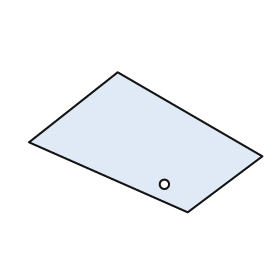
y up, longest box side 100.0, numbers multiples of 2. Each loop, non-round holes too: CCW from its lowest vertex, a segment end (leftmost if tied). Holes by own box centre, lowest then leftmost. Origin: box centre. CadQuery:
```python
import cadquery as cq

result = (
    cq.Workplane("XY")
    .moveTo(18.0, -30.0)
    .lineTo(50.0, -6.0)
    .lineTo(-12.0, 30.0)
    .lineTo(-50.0, 0.0)
    .close()
    .moveTo(8.0, -18.0)
    .circle(2.0)
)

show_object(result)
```